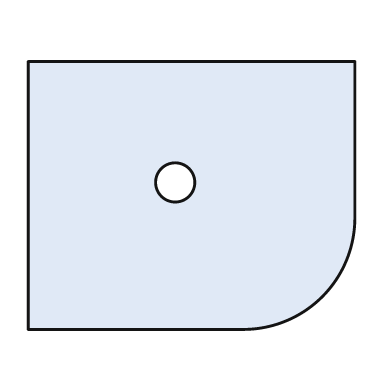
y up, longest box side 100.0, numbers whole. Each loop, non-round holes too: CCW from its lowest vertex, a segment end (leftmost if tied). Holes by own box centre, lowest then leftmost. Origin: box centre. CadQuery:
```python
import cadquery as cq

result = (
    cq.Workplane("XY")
    .moveTo(-50.0, -41.0)
    .lineTo(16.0, -41.0)
    .threePointArc((40.0, -31.0), (50.0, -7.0))
    .lineTo(50.0, 41.0)
    .lineTo(-50.0, 41.0)
    .close()
    .moveTo(-5.0, 4.0)
    .circle(6.0)
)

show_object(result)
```